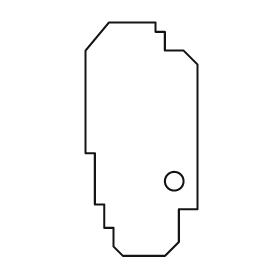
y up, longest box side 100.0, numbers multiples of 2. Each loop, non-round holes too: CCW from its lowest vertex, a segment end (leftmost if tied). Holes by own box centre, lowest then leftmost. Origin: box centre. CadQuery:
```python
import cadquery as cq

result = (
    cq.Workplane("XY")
    .moveTo(-8.0, -50.0)
    .lineTo(10.0, -50.0)
    .lineTo(16.0, -44.0)
    .lineTo(16.0, -30.0)
    .lineTo(24.0, -30.0)
    .lineTo(24.0, 32.0)
    .lineTo(18.0, 38.0)
    .lineTo(10.0, 38.0)
    .lineTo(10.0, 46.0)
    .lineTo(6.0, 46.0)
    .lineTo(6.0, 50.0)
    .lineTo(-14.0, 50.0)
    .lineTo(-24.0, 38.0)
    .lineTo(-24.0, -6.0)
    .lineTo(-20.0, -6.0)
    .lineTo(-20.0, -28.0)
    .lineTo(-16.0, -28.0)
    .lineTo(-16.0, -38.0)
    .lineTo(-12.0, -38.0)
    .lineTo(-12.0, -46.0)
    .close()
    .moveTo(14.0, -18.0)
    .circle(4.0)
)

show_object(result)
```